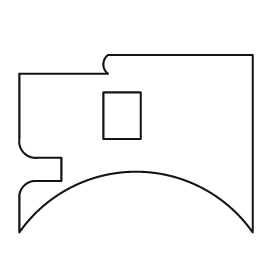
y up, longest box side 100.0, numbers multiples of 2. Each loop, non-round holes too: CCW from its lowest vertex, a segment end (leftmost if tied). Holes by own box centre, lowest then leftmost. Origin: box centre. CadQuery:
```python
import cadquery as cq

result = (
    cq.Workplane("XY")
    .moveTo(-50.0, -38.0)
    .threePointArc((0.0, -12.0), (50.0, -38.0))
    .lineTo(50.0, 38.0)
    .lineTo(-12.0, 38.0)
    .threePointArc((-14.0, 34.0), (-12.0, 30.0))
    .lineTo(-50.0, 30.0)
    .lineTo(-50.0, 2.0)
    .threePointArc((-48.0, -4.0), (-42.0, -6.0))
    .lineTo(-32.0, -6.0)
    .lineTo(-32.0, -16.0)
    .lineTo(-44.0, -16.0)
    .threePointArc((-48.0, -18.0), (-50.0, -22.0))
    .close()
    .moveTo(-14.0, 2.0)
    .lineTo(2.0, 2.0)
    .lineTo(2.0, 22.0)
    .lineTo(-14.0, 22.0)
    .close()
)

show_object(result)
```